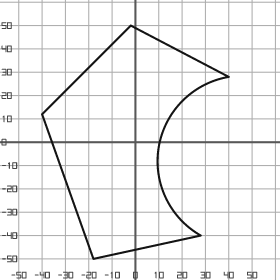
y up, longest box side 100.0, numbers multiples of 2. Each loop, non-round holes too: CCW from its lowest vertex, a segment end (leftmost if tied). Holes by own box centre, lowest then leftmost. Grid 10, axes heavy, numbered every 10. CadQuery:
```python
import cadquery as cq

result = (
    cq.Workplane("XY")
    .moveTo(-18.0, -50.0)
    .lineTo(28.0, -40.0)
    .threePointArc((10.0, -2.0), (40.0, 28.0))
    .lineTo(-2.0, 50.0)
    .lineTo(-40.0, 12.0)
    .close()
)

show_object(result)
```